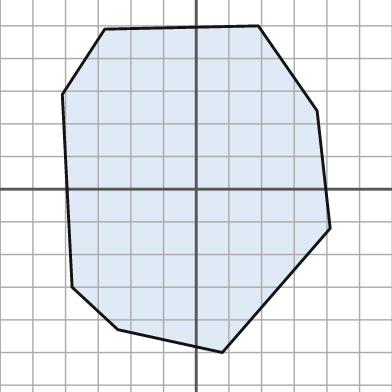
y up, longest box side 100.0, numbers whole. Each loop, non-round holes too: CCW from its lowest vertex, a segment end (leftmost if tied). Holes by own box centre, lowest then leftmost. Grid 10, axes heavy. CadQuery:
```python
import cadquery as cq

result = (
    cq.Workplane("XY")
    .moveTo(8.0, -50.0)
    .lineTo(41.0, -12.0)
    .lineTo(37.0, 24.0)
    .lineTo(19.0, 50.0)
    .lineTo(-28.0, 49.0)
    .lineTo(-41.0, 29.0)
    .lineTo(-38.0, -30.0)
    .lineTo(-24.0, -43.0)
    .close()
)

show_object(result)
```